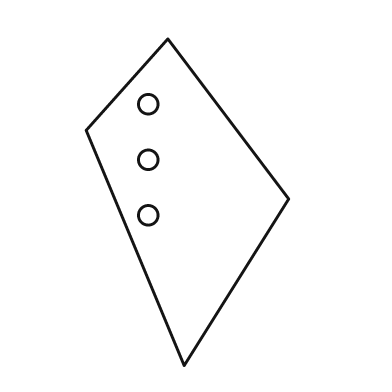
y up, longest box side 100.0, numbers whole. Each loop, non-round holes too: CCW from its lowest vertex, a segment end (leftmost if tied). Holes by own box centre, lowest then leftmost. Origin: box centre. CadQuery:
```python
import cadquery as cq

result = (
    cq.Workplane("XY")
    .moveTo(-1.0, -50.0)
    .lineTo(31.0, 1.0)
    .lineTo(-6.0, 50.0)
    .lineTo(-31.0, 22.0)
    .close()
    .moveTo(-12.0, -4.0)
    .circle(3.0)
    .moveTo(-12.0, 13.0)
    .circle(3.0)
    .moveTo(-12.0, 30.0)
    .circle(3.0)
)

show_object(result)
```